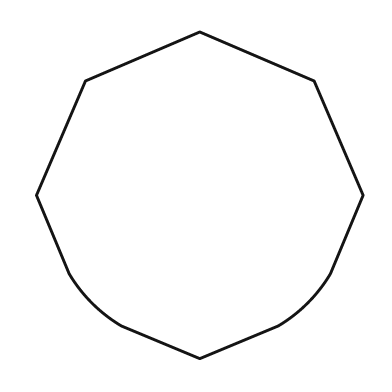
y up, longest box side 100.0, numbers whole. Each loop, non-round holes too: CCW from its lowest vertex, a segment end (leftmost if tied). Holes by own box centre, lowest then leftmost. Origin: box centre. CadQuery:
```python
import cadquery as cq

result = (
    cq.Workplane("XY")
    .moveTo(0.0, -50.0)
    .lineTo(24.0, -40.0)
    .threePointArc((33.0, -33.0), (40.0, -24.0))
    .lineTo(50.0, 0.0)
    .lineTo(35.0, 35.0)
    .lineTo(0.0, 50.0)
    .lineTo(-35.0, 35.0)
    .lineTo(-50.0, 0.0)
    .lineTo(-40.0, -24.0)
    .threePointArc((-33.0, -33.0), (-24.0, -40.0))
    .close()
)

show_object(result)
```